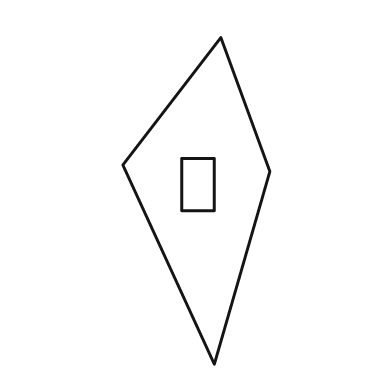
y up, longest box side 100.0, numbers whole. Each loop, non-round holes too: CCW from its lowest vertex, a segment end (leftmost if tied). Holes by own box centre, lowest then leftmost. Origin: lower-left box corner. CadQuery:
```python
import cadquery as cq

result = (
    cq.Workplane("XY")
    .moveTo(28.0, 0.0)
    .lineTo(45.0, 59.0)
    .lineTo(30.0, 100.0)
    .lineTo(0.0, 61.0)
    .close()
    .moveTo(18.0, 47.0)
    .lineTo(28.0, 47.0)
    .lineTo(28.0, 63.0)
    .lineTo(18.0, 63.0)
    .close()
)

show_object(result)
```